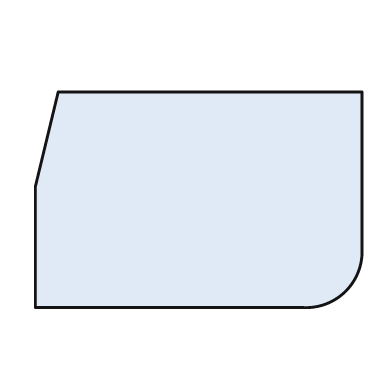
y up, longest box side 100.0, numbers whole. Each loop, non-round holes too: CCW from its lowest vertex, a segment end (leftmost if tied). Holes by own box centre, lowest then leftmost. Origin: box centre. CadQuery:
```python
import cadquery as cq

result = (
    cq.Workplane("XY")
    .moveTo(-50.0, -33.0)
    .lineTo(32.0, -33.0)
    .threePointArc((45.0, -28.0), (50.0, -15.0))
    .lineTo(50.0, 33.0)
    .lineTo(-43.0, 33.0)
    .lineTo(-50.0, 4.0)
    .close()
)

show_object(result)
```